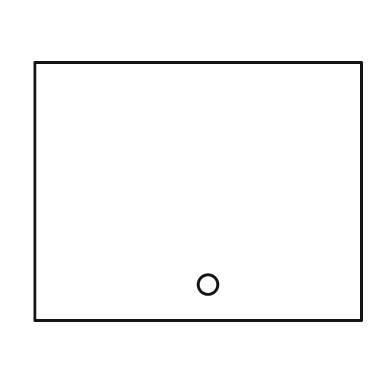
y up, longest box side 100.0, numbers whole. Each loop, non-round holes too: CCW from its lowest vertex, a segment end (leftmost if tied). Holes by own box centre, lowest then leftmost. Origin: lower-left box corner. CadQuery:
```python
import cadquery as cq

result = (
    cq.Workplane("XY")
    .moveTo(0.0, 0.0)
    .lineTo(100.0, 0.0)
    .lineTo(100.0, 79.0)
    .lineTo(0.0, 79.0)
    .close()
    .moveTo(53.0, 11.0)
    .circle(3.0)
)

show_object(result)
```